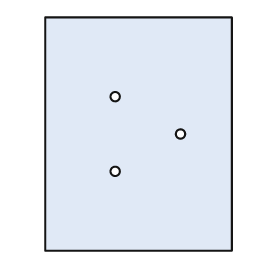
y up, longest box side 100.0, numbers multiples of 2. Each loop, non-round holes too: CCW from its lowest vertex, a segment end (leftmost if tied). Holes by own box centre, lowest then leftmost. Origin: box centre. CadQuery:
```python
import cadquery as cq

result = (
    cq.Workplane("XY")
    .moveTo(-40.0, -50.0)
    .lineTo(40.0, -50.0)
    .lineTo(40.0, 50.0)
    .lineTo(-40.0, 50.0)
    .close()
    .moveTo(-10.0, -16.0)
    .circle(2.0)
    .moveTo(18.0, 0.0)
    .circle(2.0)
    .moveTo(-10.0, 16.0)
    .circle(2.0)
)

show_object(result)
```